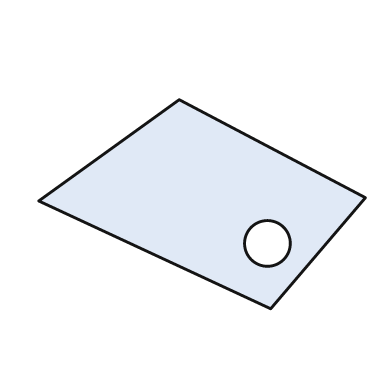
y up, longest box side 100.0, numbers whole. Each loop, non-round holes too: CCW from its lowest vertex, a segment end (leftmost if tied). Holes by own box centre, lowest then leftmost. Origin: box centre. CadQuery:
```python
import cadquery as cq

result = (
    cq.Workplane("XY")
    .moveTo(21.0, -32.0)
    .lineTo(50.0, 2.0)
    .lineTo(-7.0, 32.0)
    .lineTo(-50.0, 1.0)
    .close()
    .moveTo(20.0, -12.0)
    .circle(7.0)
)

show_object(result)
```